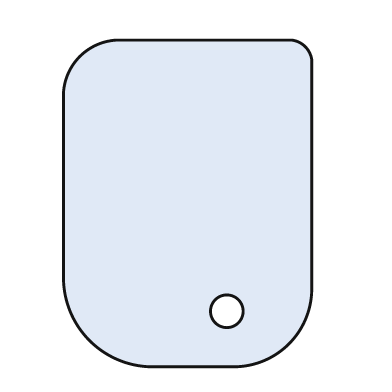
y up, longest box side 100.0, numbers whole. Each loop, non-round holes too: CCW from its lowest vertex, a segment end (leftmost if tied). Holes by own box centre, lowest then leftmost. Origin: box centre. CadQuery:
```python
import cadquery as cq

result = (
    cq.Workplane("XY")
    .moveTo(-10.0, -50.0)
    .lineTo(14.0, -50.0)
    .threePointArc((31.0, -43.0), (38.0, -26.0))
    .lineTo(38.0, 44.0)
    .threePointArc((36.0, 48.0), (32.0, 50.0))
    .lineTo(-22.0, 50.0)
    .threePointArc((-33.0, 45.0), (-38.0, 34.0))
    .lineTo(-38.0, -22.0)
    .threePointArc((-30.0, -42.0), (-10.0, -50.0))
    .close()
    .moveTo(12.0, -33.0)
    .circle(5.0)
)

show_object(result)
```